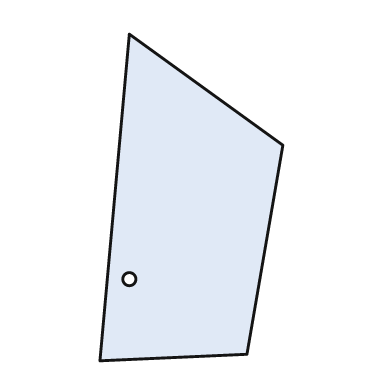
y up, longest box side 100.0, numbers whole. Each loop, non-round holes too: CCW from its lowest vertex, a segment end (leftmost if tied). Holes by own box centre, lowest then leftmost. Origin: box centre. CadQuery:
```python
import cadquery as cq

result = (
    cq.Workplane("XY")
    .moveTo(-28.0, -50.0)
    .lineTo(17.0, -48.0)
    .lineTo(28.0, 16.0)
    .lineTo(-19.0, 50.0)
    .close()
    .moveTo(-19.0, -25.0)
    .circle(2.0)
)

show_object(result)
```